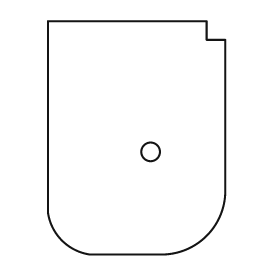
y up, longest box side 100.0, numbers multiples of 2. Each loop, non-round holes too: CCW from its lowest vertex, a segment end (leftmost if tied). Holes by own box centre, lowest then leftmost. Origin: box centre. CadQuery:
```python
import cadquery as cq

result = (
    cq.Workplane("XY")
    .moveTo(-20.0, -50.0)
    .lineTo(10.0, -50.0)
    .threePointArc((30.0, -42.0), (38.0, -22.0))
    .lineTo(38.0, 42.0)
    .lineTo(30.0, 42.0)
    .lineTo(30.0, 50.0)
    .lineTo(-38.0, 50.0)
    .lineTo(-38.0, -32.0)
    .threePointArc((-32.0, -44.0), (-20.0, -50.0))
    .close()
    .moveTo(6.0, -6.0)
    .circle(4.0)
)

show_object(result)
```